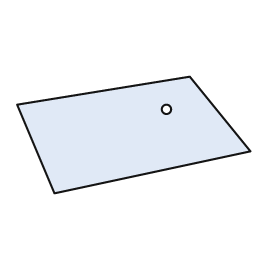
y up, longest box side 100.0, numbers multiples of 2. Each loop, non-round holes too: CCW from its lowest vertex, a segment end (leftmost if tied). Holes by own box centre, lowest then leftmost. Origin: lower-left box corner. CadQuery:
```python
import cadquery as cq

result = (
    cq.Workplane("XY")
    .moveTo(16.0, 0.0)
    .lineTo(100.0, 18.0)
    .lineTo(74.0, 50.0)
    .lineTo(0.0, 38.0)
    .close()
    .moveTo(64.0, 36.0)
    .circle(2.0)
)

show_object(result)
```